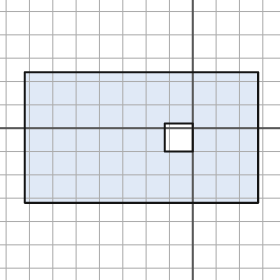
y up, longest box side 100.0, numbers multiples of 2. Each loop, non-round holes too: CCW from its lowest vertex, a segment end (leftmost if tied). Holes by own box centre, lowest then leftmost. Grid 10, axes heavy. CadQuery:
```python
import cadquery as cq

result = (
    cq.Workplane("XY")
    .moveTo(-72.0, -32.0)
    .lineTo(28.0, -32.0)
    .lineTo(28.0, 24.0)
    .lineTo(-72.0, 24.0)
    .close()
    .moveTo(-12.0, -10.0)
    .lineTo(0.0, -10.0)
    .lineTo(0.0, 2.0)
    .lineTo(-12.0, 2.0)
    .close()
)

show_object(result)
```